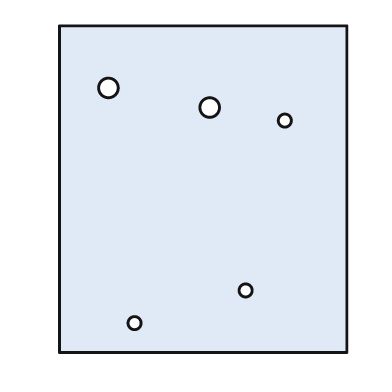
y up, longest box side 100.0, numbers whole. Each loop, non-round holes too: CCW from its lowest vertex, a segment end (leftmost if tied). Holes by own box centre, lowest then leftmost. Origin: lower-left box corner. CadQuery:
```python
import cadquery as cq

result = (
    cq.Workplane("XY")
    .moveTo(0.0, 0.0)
    .lineTo(88.0, 0.0)
    .lineTo(88.0, 100.0)
    .lineTo(0.0, 100.0)
    .close()
    .moveTo(23.0, 9.0)
    .circle(2.0)
    .moveTo(57.0, 19.0)
    .circle(2.0)
    .moveTo(69.0, 71.0)
    .circle(2.0)
    .moveTo(46.0, 75.0)
    .circle(3.0)
    .moveTo(15.0, 81.0)
    .circle(3.0)
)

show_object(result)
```